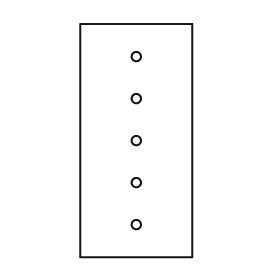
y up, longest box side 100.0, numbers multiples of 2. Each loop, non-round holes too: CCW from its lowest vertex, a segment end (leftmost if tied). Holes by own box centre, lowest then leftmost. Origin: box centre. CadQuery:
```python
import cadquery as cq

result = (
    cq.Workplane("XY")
    .moveTo(-24.0, -50.0)
    .lineTo(24.0, -50.0)
    .lineTo(24.0, 50.0)
    .lineTo(-24.0, 50.0)
    .close()
    .moveTo(0.0, -36.0)
    .circle(2.0)
    .moveTo(0.0, -18.0)
    .circle(2.0)
    .moveTo(0.0, 0.0)
    .circle(2.0)
    .moveTo(0.0, 18.0)
    .circle(2.0)
    .moveTo(0.0, 36.0)
    .circle(2.0)
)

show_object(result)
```